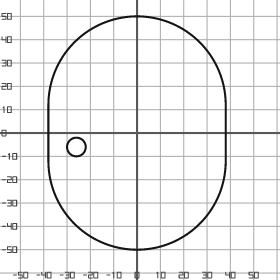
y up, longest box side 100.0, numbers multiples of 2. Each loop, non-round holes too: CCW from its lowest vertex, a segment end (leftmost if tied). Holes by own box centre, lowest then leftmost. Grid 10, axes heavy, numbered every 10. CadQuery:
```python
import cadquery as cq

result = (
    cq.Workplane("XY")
    .moveTo(-38.0, -12.0)
    .threePointArc((0.0, -50.0), (38.0, -12.0))
    .lineTo(38.0, 12.0)
    .threePointArc((0.0, 50.0), (-38.0, 12.0))
    .close()
    .moveTo(-26.0, -6.0)
    .circle(4.0)
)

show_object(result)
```